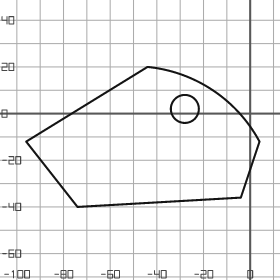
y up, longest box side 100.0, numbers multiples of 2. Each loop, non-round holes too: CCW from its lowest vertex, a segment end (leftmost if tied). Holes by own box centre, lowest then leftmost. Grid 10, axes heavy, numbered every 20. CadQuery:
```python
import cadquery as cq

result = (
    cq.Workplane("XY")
    .moveTo(-74.0, -40.0)
    .lineTo(-4.0, -36.0)
    .lineTo(4.0, -12.0)
    .threePointArc((-16.0, 10.0), (-44.0, 20.0))
    .lineTo(-96.0, -12.0)
    .close()
    .moveTo(-28.0, 2.0)
    .circle(6.0)
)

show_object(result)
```